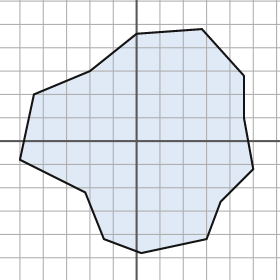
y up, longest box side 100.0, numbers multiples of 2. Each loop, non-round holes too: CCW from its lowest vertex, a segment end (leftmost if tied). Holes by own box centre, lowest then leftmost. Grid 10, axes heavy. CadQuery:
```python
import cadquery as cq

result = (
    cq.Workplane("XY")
    .moveTo(2.0, -48.0)
    .lineTo(30.0, -42.0)
    .lineTo(36.0, -26.0)
    .lineTo(50.0, -12.0)
    .lineTo(46.0, 10.0)
    .lineTo(46.0, 28.0)
    .lineTo(28.0, 48.0)
    .lineTo(0.0, 46.0)
    .lineTo(-20.0, 30.0)
    .lineTo(-44.0, 20.0)
    .lineTo(-50.0, -8.0)
    .lineTo(-22.0, -22.0)
    .lineTo(-14.0, -42.0)
    .close()
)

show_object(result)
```